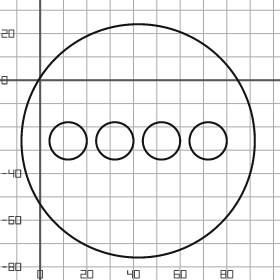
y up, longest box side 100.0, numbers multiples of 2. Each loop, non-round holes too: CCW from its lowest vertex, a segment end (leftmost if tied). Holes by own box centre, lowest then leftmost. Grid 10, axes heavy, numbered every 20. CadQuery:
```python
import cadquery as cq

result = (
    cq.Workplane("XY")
    .moveTo(42.0, -26.0)
    .circle(50.0)
    .moveTo(12.0, -26.0)
    .circle(8.0)
    .moveTo(32.0, -26.0)
    .circle(8.0)
    .moveTo(52.0, -26.0)
    .circle(8.0)
    .moveTo(72.0, -26.0)
    .circle(8.0)
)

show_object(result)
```